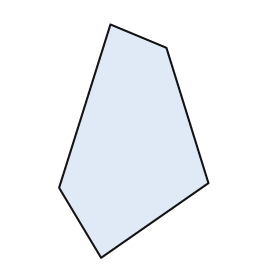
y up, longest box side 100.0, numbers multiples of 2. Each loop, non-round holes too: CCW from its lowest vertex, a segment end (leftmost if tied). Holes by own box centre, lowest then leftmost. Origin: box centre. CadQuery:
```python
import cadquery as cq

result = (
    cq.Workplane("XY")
    .moveTo(-14.0, -50.0)
    .lineTo(32.0, -18.0)
    .lineTo(14.0, 40.0)
    .lineTo(-10.0, 50.0)
    .lineTo(-32.0, -20.0)
    .close()
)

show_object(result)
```